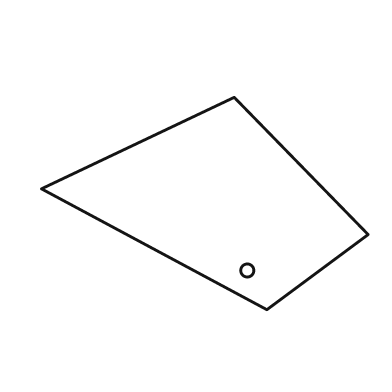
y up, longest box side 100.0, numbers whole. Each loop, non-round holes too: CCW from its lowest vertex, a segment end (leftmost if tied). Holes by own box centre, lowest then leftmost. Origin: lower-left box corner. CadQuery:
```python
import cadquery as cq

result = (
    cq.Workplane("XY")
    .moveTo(69.0, 0.0)
    .lineTo(100.0, 23.0)
    .lineTo(59.0, 65.0)
    .lineTo(0.0, 37.0)
    .close()
    .moveTo(63.0, 12.0)
    .circle(2.0)
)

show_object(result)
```